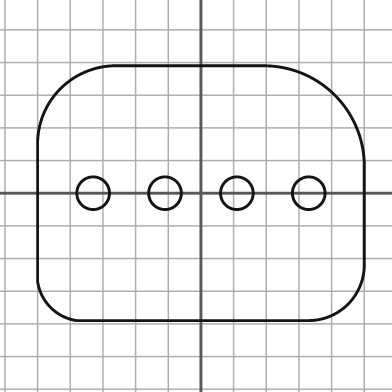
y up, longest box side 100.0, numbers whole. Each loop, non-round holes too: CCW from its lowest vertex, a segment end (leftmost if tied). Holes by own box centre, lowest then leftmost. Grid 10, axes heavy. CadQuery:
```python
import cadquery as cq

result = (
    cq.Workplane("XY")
    .moveTo(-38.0, -39.0)
    .lineTo(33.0, -39.0)
    .threePointArc((45.0, -34.0), (50.0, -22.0))
    .lineTo(50.0, 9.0)
    .threePointArc((41.0, 30.0), (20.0, 39.0))
    .lineTo(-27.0, 39.0)
    .threePointArc((-43.0, 32.0), (-50.0, 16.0))
    .lineTo(-50.0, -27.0)
    .threePointArc((-46.0, -35.0), (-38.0, -39.0))
    .close()
    .moveTo(-33.0, 0.0)
    .circle(5.0)
    .moveTo(-11.0, 0.0)
    .circle(5.0)
    .moveTo(11.0, 0.0)
    .circle(5.0)
    .moveTo(33.0, 0.0)
    .circle(5.0)
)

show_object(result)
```